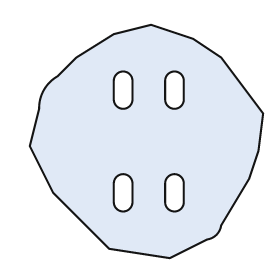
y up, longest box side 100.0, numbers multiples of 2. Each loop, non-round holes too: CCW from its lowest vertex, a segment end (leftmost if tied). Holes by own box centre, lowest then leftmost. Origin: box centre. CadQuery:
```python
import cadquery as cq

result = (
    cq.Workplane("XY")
    .moveTo(10.0, -50.0)
    .lineTo(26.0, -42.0)
    .threePointArc((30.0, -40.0), (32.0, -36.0))
    .lineTo(44.0, -16.0)
    .lineTo(48.0, -4.0)
    .lineTo(50.0, 12.0)
    .lineTo(32.0, 36.0)
    .lineTo(20.0, 44.0)
    .lineTo(2.0, 50.0)
    .lineTo(-14.0, 46.0)
    .lineTo(-30.0, 36.0)
    .lineTo(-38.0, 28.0)
    .threePointArc((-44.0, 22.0), (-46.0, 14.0))
    .lineTo(-50.0, -2.0)
    .lineTo(-40.0, -22.0)
    .lineTo(-16.0, -46.0)
    .close()
    .moveTo(-14.0, -26.0)
    .threePointArc((-10.0, -30.0), (-6.0, -26.0))
    .lineTo(-6.0, -18.0)
    .threePointArc((-10.0, -14.0), (-14.0, -18.0))
    .close()
    .moveTo(8.0, -26.0)
    .threePointArc((12.0, -30.0), (16.0, -26.0))
    .lineTo(16.0, -18.0)
    .threePointArc((12.0, -14.0), (8.0, -18.0))
    .close()
    .moveTo(-14.0, 18.0)
    .threePointArc((-10.0, 14.0), (-6.0, 18.0))
    .lineTo(-6.0, 26.0)
    .threePointArc((-10.0, 30.0), (-14.0, 26.0))
    .close()
    .moveTo(8.0, 18.0)
    .threePointArc((12.0, 14.0), (16.0, 18.0))
    .lineTo(16.0, 26.0)
    .threePointArc((12.0, 30.0), (8.0, 26.0))
    .close()
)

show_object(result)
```